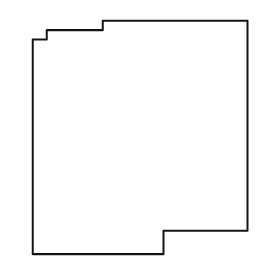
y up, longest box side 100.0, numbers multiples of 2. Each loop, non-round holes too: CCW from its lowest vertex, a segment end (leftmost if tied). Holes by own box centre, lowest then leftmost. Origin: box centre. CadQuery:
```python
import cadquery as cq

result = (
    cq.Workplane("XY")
    .moveTo(-46.0, -50.0)
    .lineTo(10.0, -50.0)
    .lineTo(10.0, -40.0)
    .lineTo(46.0, -40.0)
    .lineTo(46.0, 50.0)
    .lineTo(-16.0, 50.0)
    .lineTo(-16.0, 46.0)
    .lineTo(-40.0, 46.0)
    .lineTo(-40.0, 42.0)
    .lineTo(-46.0, 42.0)
    .close()
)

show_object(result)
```